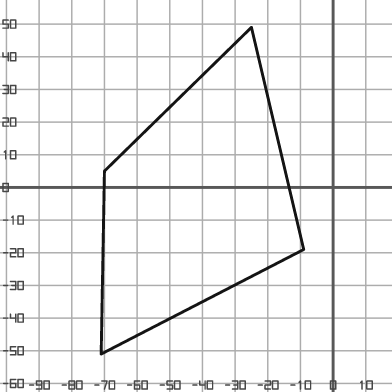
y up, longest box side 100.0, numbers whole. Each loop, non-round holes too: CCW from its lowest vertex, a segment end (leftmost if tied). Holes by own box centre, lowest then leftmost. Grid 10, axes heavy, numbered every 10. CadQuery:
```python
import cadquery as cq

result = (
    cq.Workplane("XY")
    .moveTo(-71.0, -51.0)
    .lineTo(-9.0, -19.0)
    .lineTo(-25.0, 49.0)
    .lineTo(-70.0, 5.0)
    .close()
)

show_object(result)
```